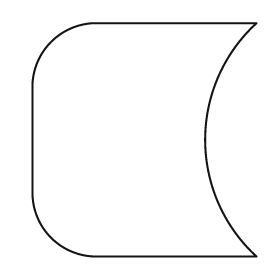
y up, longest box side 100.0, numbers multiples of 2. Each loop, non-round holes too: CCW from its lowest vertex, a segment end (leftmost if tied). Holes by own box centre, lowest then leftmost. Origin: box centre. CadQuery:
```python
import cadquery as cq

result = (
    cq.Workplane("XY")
    .moveTo(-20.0, -50.0)
    .lineTo(48.0, -50.0)
    .threePointArc((26.0, 0.0), (48.0, 50.0))
    .lineTo(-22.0, 50.0)
    .threePointArc((-40.0, 42.0), (-48.0, 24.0))
    .lineTo(-48.0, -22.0)
    .threePointArc((-40.0, -42.0), (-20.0, -50.0))
    .close()
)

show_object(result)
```